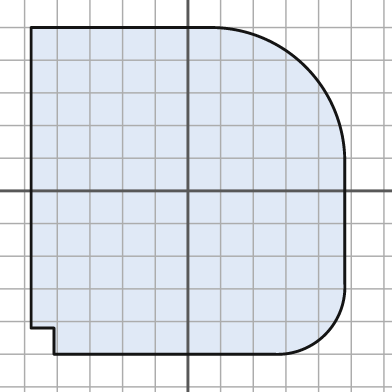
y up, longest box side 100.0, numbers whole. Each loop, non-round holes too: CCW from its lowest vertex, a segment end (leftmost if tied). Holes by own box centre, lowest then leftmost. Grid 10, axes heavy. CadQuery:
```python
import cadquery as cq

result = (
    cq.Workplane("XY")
    .moveTo(-41.0, -50.0)
    .lineTo(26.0, -50.0)
    .threePointArc((42.0, -44.0), (48.0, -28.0))
    .lineTo(48.0, 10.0)
    .threePointArc((36.0, 38.0), (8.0, 50.0))
    .lineTo(-48.0, 50.0)
    .lineTo(-48.0, -42.0)
    .lineTo(-41.0, -42.0)
    .close()
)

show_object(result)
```